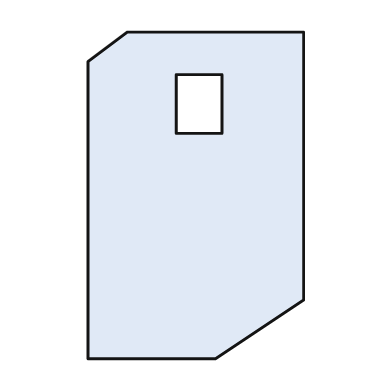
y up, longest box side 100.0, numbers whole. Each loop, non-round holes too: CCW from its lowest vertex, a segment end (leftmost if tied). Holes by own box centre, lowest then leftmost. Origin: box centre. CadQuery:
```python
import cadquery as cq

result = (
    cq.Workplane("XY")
    .moveTo(-33.0, -50.0)
    .lineTo(6.0, -50.0)
    .lineTo(33.0, -32.0)
    .lineTo(33.0, 50.0)
    .lineTo(-21.0, 50.0)
    .lineTo(-33.0, 41.0)
    .close()
    .moveTo(-6.0, 19.0)
    .lineTo(8.0, 19.0)
    .lineTo(8.0, 37.0)
    .lineTo(-6.0, 37.0)
    .close()
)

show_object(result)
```